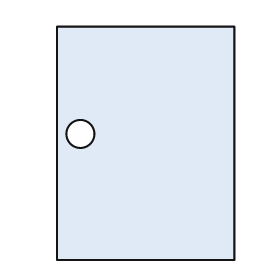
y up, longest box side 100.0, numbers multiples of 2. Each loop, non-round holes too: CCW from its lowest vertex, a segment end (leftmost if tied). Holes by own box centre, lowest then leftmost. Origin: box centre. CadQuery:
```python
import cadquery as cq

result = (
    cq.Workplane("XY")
    .moveTo(-38.0, -50.0)
    .lineTo(38.0, -50.0)
    .lineTo(38.0, 50.0)
    .lineTo(-38.0, 50.0)
    .close()
    .moveTo(-28.0, 4.0)
    .circle(6.0)
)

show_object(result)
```